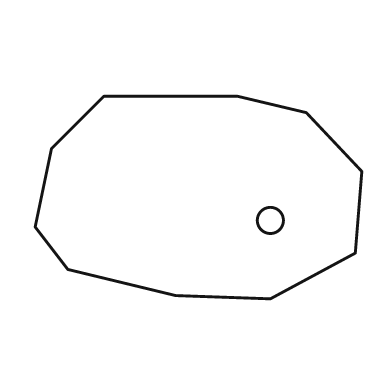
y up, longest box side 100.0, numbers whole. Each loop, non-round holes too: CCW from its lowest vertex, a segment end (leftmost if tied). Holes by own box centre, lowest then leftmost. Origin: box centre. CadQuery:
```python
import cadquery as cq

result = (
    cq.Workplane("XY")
    .moveTo(22.0, -31.0)
    .lineTo(48.0, -17.0)
    .lineTo(50.0, 8.0)
    .lineTo(33.0, 26.0)
    .lineTo(12.0, 31.0)
    .lineTo(-29.0, 31.0)
    .lineTo(-45.0, 15.0)
    .lineTo(-50.0, -9.0)
    .lineTo(-40.0, -22.0)
    .lineTo(-7.0, -30.0)
    .close()
    .moveTo(22.0, -7.0)
    .circle(4.0)
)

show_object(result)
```